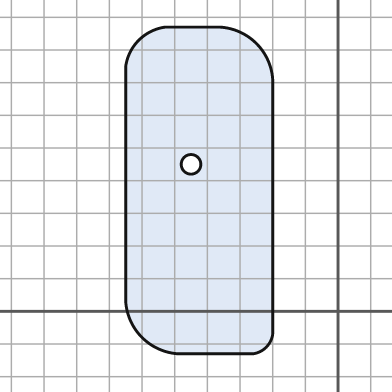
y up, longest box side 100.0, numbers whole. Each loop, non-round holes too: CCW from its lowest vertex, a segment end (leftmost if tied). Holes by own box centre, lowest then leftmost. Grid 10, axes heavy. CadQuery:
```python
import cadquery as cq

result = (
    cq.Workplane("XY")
    .moveTo(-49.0, -13.0)
    .lineTo(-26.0, -13.0)
    .threePointArc((-22.0, -11.0), (-20.0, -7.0))
    .lineTo(-20.0, 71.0)
    .threePointArc((-25.0, 82.0), (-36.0, 87.0))
    .lineTo(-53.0, 87.0)
    .threePointArc((-61.0, 83.0), (-65.0, 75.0))
    .lineTo(-65.0, 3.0)
    .threePointArc((-60.0, -8.0), (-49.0, -13.0))
    .close()
    .moveTo(-45.0, 45.0)
    .circle(3.0)
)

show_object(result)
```